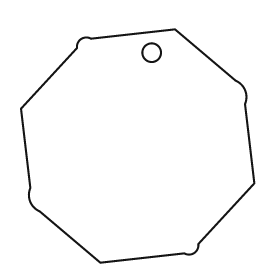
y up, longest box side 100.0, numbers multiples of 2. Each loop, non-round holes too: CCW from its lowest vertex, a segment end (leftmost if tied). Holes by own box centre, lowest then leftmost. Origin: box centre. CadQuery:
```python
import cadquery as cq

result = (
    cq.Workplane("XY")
    .moveTo(-16.0, -50.0)
    .lineTo(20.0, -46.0)
    .threePointArc((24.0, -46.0), (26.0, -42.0))
    .lineTo(50.0, -16.0)
    .lineTo(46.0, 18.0)
    .threePointArc((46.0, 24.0), (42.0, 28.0))
    .lineTo(16.0, 50.0)
    .lineTo(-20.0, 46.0)
    .threePointArc((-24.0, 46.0), (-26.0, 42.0))
    .lineTo(-50.0, 16.0)
    .lineTo(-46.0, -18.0)
    .threePointArc((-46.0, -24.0), (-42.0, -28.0))
    .close()
    .moveTo(6.0, 40.0)
    .circle(4.0)
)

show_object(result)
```